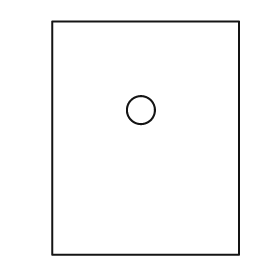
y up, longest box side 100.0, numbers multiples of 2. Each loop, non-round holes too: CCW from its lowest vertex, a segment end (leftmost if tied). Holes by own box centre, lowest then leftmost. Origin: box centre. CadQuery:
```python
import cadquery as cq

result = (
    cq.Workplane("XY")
    .moveTo(-40.0, -50.0)
    .lineTo(40.0, -50.0)
    .lineTo(40.0, 50.0)
    .lineTo(-40.0, 50.0)
    .close()
    .moveTo(-2.0, 12.0)
    .circle(6.0)
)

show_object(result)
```